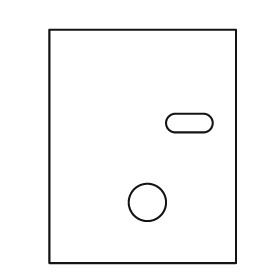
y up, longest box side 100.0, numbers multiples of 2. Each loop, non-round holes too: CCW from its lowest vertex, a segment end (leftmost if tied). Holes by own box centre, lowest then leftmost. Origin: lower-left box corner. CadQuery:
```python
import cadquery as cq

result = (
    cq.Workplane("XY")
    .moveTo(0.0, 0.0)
    .lineTo(80.0, 0.0)
    .lineTo(80.0, 100.0)
    .lineTo(0.0, 100.0)
    .close()
    .moveTo(42.0, 26.0)
    .circle(8.0)
    .moveTo(54.0, 56.0)
    .lineTo(66.0, 56.0)
    .threePointArc((70.0, 60.0), (66.0, 64.0))
    .lineTo(54.0, 64.0)
    .threePointArc((50.0, 60.0), (54.0, 56.0))
    .close()
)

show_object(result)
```